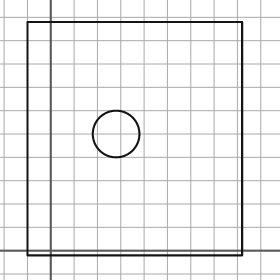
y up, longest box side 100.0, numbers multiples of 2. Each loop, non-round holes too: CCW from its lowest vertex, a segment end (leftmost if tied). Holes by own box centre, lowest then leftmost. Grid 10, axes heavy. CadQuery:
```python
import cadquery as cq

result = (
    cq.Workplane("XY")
    .moveTo(-10.0, -2.0)
    .lineTo(82.0, -2.0)
    .lineTo(82.0, 98.0)
    .lineTo(-10.0, 98.0)
    .close()
    .moveTo(28.0, 50.0)
    .circle(10.0)
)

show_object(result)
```